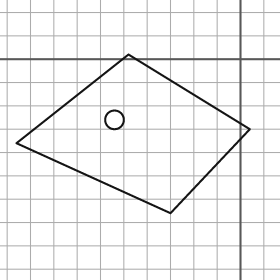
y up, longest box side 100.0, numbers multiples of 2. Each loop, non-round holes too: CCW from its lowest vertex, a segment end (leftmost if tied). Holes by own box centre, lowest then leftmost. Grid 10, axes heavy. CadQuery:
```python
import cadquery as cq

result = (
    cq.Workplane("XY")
    .moveTo(-30.0, -66.0)
    .lineTo(4.0, -30.0)
    .lineTo(-48.0, 2.0)
    .lineTo(-96.0, -36.0)
    .close()
    .moveTo(-54.0, -26.0)
    .circle(4.0)
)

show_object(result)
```